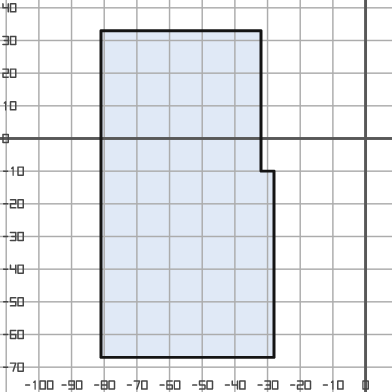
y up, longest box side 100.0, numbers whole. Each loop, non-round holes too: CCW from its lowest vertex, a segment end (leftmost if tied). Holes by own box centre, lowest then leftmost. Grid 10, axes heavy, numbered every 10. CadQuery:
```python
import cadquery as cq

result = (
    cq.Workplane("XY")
    .moveTo(-81.0, -67.0)
    .lineTo(-28.0, -67.0)
    .lineTo(-28.0, -10.0)
    .lineTo(-32.0, -10.0)
    .lineTo(-32.0, 33.0)
    .lineTo(-81.0, 33.0)
    .close()
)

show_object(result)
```